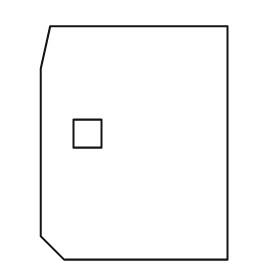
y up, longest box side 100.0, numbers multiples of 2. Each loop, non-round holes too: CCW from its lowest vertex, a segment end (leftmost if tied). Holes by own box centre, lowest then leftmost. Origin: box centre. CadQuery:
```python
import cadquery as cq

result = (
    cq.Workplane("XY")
    .moveTo(-30.0, -50.0)
    .lineTo(40.0, -50.0)
    .lineTo(40.0, 50.0)
    .lineTo(-36.0, 50.0)
    .lineTo(-40.0, 32.0)
    .lineTo(-40.0, -40.0)
    .close()
    .moveTo(-26.0, -2.0)
    .lineTo(-14.0, -2.0)
    .lineTo(-14.0, 10.0)
    .lineTo(-26.0, 10.0)
    .close()
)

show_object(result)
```